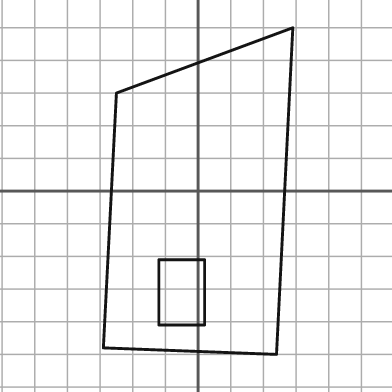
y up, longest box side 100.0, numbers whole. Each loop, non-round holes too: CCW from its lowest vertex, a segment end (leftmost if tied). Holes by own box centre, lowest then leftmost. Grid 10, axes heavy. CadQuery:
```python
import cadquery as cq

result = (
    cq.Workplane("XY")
    .moveTo(24.0, -50.0)
    .lineTo(29.0, 50.0)
    .lineTo(-25.0, 30.0)
    .lineTo(-29.0, -48.0)
    .close()
    .moveTo(-12.0, -41.0)
    .lineTo(2.0, -41.0)
    .lineTo(2.0, -21.0)
    .lineTo(-12.0, -21.0)
    .close()
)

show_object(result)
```